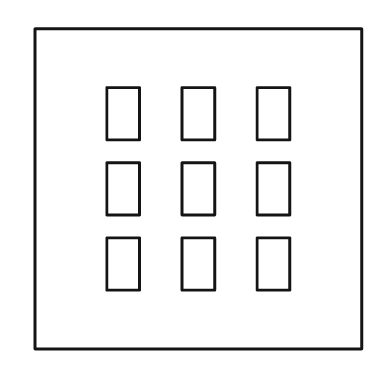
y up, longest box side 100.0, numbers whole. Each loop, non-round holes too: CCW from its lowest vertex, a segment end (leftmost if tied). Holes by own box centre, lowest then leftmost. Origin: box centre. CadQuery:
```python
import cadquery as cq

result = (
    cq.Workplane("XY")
    .moveTo(-50.0, -49.0)
    .lineTo(50.0, -49.0)
    .lineTo(50.0, 49.0)
    .lineTo(-50.0, 49.0)
    .close()
    .moveTo(-28.0, -31.0)
    .lineTo(-18.0, -31.0)
    .lineTo(-18.0, -15.0)
    .lineTo(-28.0, -15.0)
    .close()
    .moveTo(-5.0, -31.0)
    .lineTo(5.0, -31.0)
    .lineTo(5.0, -15.0)
    .lineTo(-5.0, -15.0)
    .close()
    .moveTo(18.0, -31.0)
    .lineTo(28.0, -31.0)
    .lineTo(28.0, -15.0)
    .lineTo(18.0, -15.0)
    .close()
    .moveTo(-28.0, -8.0)
    .lineTo(-18.0, -8.0)
    .lineTo(-18.0, 8.0)
    .lineTo(-28.0, 8.0)
    .close()
    .moveTo(-5.0, -8.0)
    .lineTo(5.0, -8.0)
    .lineTo(5.0, 8.0)
    .lineTo(-5.0, 8.0)
    .close()
    .moveTo(18.0, -8.0)
    .lineTo(28.0, -8.0)
    .lineTo(28.0, 8.0)
    .lineTo(18.0, 8.0)
    .close()
    .moveTo(-28.0, 15.0)
    .lineTo(-18.0, 15.0)
    .lineTo(-18.0, 31.0)
    .lineTo(-28.0, 31.0)
    .close()
    .moveTo(-5.0, 15.0)
    .lineTo(5.0, 15.0)
    .lineTo(5.0, 31.0)
    .lineTo(-5.0, 31.0)
    .close()
    .moveTo(18.0, 15.0)
    .lineTo(28.0, 15.0)
    .lineTo(28.0, 31.0)
    .lineTo(18.0, 31.0)
    .close()
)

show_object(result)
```